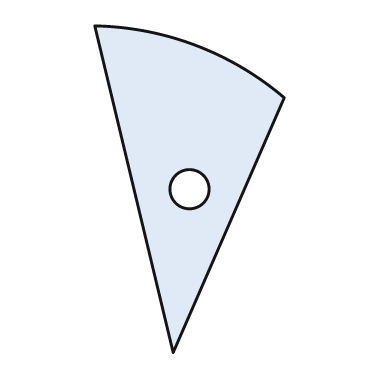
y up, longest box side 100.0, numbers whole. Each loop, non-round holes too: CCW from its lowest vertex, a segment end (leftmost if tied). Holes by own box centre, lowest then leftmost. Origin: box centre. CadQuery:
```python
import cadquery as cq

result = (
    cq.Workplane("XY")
    .moveTo(-5.0, -50.0)
    .lineTo(29.0, 28.0)
    .threePointArc((2.0, 44.0), (-29.0, 50.0))
    .close()
    .moveTo(0.0, 0.0)
    .circle(6.0)
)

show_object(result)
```